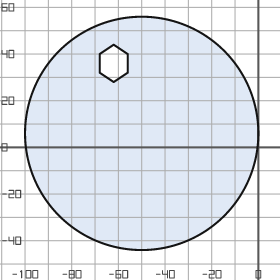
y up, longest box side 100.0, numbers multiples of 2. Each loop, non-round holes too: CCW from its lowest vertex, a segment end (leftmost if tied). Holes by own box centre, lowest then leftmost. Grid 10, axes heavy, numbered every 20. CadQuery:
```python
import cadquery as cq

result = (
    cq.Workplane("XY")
    .moveTo(-50.0, 6.0)
    .circle(50.0)
    .moveTo(-62.0, 28.0)
    .lineTo(-56.0, 32.0)
    .lineTo(-56.0, 40.0)
    .lineTo(-62.0, 44.0)
    .lineTo(-68.0, 40.0)
    .lineTo(-68.0, 32.0)
    .close()
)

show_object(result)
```